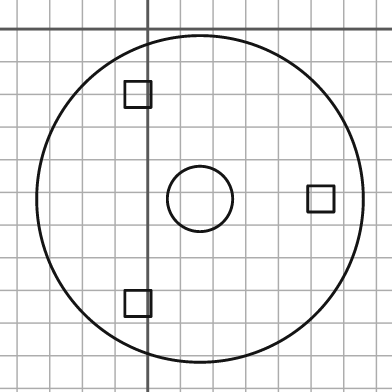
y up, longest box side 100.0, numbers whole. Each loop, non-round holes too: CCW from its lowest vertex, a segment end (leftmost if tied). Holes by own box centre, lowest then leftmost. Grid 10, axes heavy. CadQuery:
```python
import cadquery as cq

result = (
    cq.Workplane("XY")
    .moveTo(16.0, -52.0)
    .circle(50.0)
    .moveTo(-7.0, -88.0)
    .lineTo(1.0, -88.0)
    .lineTo(1.0, -80.0)
    .lineTo(-7.0, -80.0)
    .close()
    .moveTo(16.0, -52.0)
    .circle(10.0)
    .moveTo(49.0, -56.0)
    .lineTo(57.0, -56.0)
    .lineTo(57.0, -48.0)
    .lineTo(49.0, -48.0)
    .close()
    .moveTo(-7.0, -24.0)
    .lineTo(1.0, -24.0)
    .lineTo(1.0, -16.0)
    .lineTo(-7.0, -16.0)
    .close()
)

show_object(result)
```